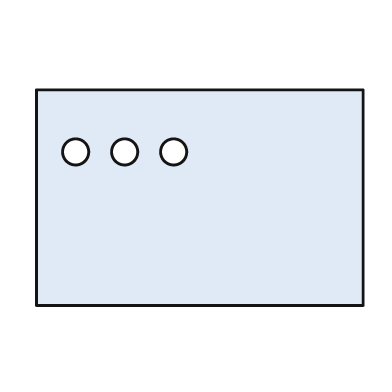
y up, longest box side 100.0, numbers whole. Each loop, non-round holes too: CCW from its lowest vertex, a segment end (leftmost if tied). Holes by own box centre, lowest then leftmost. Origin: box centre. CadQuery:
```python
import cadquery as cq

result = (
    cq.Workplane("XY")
    .moveTo(-50.0, -33.0)
    .lineTo(50.0, -33.0)
    .lineTo(50.0, 33.0)
    .lineTo(-50.0, 33.0)
    .close()
    .moveTo(-38.0, 14.0)
    .circle(4.0)
    .moveTo(-23.0, 14.0)
    .circle(4.0)
    .moveTo(-8.0, 14.0)
    .circle(4.0)
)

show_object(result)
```